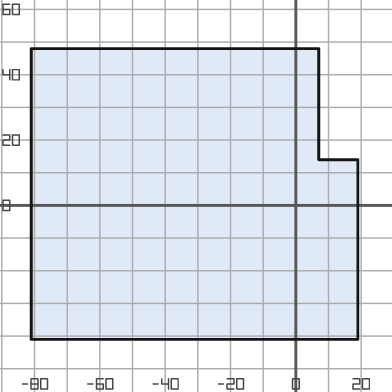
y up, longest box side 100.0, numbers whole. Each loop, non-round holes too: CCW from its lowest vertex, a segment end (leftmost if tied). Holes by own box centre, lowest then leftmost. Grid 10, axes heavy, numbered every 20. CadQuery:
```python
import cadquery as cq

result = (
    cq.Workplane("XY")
    .moveTo(-81.0, -41.0)
    .lineTo(19.0, -41.0)
    .lineTo(19.0, 14.0)
    .lineTo(7.0, 14.0)
    .lineTo(7.0, 48.0)
    .lineTo(-81.0, 48.0)
    .close()
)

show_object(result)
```